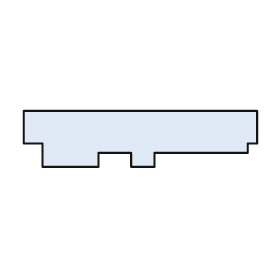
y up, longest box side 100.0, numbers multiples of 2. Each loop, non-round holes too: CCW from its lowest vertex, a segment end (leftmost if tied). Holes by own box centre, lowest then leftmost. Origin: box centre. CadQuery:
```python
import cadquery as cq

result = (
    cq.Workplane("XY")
    .moveTo(-42.0, -12.0)
    .lineTo(-18.0, -12.0)
    .lineTo(-18.0, -6.0)
    .lineTo(-4.0, -6.0)
    .lineTo(-4.0, -12.0)
    .lineTo(6.0, -12.0)
    .lineTo(6.0, -6.0)
    .lineTo(46.0, -6.0)
    .lineTo(46.0, -2.0)
    .lineTo(50.0, -2.0)
    .lineTo(50.0, 12.0)
    .lineTo(-50.0, 12.0)
    .lineTo(-50.0, -2.0)
    .lineTo(-42.0, -2.0)
    .close()
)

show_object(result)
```